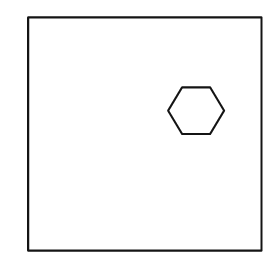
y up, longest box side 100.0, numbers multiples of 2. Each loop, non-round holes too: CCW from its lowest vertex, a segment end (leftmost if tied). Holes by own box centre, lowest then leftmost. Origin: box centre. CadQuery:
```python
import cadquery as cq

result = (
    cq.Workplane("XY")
    .moveTo(-50.0, -50.0)
    .lineTo(50.0, -50.0)
    .lineTo(50.0, 50.0)
    .lineTo(-50.0, 50.0)
    .close()
    .moveTo(16.0, 0.0)
    .lineTo(28.0, 0.0)
    .lineTo(34.0, 10.0)
    .lineTo(28.0, 20.0)
    .lineTo(16.0, 20.0)
    .lineTo(10.0, 10.0)
    .close()
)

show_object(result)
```